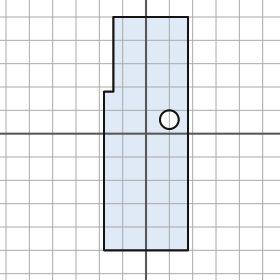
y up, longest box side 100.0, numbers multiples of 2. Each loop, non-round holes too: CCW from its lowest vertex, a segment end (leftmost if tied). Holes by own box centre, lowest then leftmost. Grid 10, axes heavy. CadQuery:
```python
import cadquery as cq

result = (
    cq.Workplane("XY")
    .moveTo(-18.0, -50.0)
    .lineTo(18.0, -50.0)
    .lineTo(18.0, 50.0)
    .lineTo(-14.0, 50.0)
    .lineTo(-14.0, 18.0)
    .lineTo(-18.0, 18.0)
    .close()
    .moveTo(10.0, 6.0)
    .circle(4.0)
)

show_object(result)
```